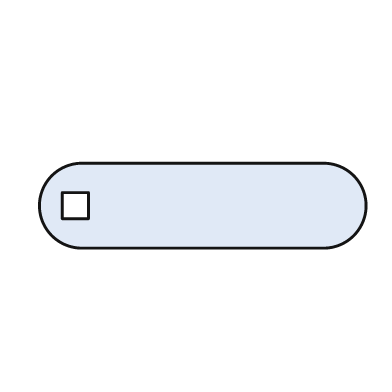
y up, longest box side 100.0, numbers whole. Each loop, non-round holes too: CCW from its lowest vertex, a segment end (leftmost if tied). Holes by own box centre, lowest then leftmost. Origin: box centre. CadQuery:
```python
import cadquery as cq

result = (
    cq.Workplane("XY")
    .moveTo(-37.0, -13.0)
    .lineTo(37.0, -13.0)
    .threePointArc((50.0, 0.0), (37.0, 13.0))
    .lineTo(-37.0, 13.0)
    .threePointArc((-50.0, 0.0), (-37.0, -13.0))
    .close()
    .moveTo(-43.0, -4.0)
    .lineTo(-35.0, -4.0)
    .lineTo(-35.0, 4.0)
    .lineTo(-43.0, 4.0)
    .close()
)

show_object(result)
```